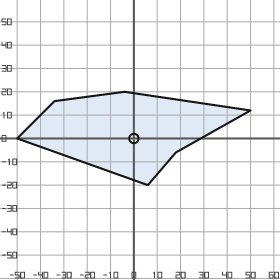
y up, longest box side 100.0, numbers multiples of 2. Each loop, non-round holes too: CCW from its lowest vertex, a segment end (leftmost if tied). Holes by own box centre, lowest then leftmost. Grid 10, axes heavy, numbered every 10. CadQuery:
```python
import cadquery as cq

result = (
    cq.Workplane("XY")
    .moveTo(6.0, -20.0)
    .lineTo(18.0, -6.0)
    .lineTo(50.0, 12.0)
    .lineTo(-4.0, 20.0)
    .lineTo(-34.0, 16.0)
    .lineTo(-50.0, 0.0)
    .close()
    .moveTo(0.0, 0.0)
    .circle(2.0)
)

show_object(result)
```